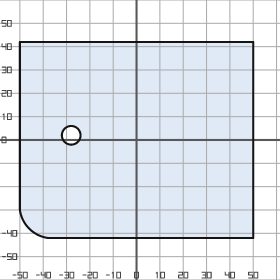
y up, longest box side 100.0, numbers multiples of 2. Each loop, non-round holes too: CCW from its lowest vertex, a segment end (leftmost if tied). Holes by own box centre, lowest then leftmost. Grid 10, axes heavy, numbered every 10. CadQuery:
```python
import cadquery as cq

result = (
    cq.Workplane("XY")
    .moveTo(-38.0, -42.0)
    .lineTo(50.0, -42.0)
    .lineTo(50.0, 42.0)
    .lineTo(-50.0, 42.0)
    .lineTo(-50.0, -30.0)
    .threePointArc((-46.0, -38.0), (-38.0, -42.0))
    .close()
    .moveTo(-28.0, 2.0)
    .circle(4.0)
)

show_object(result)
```